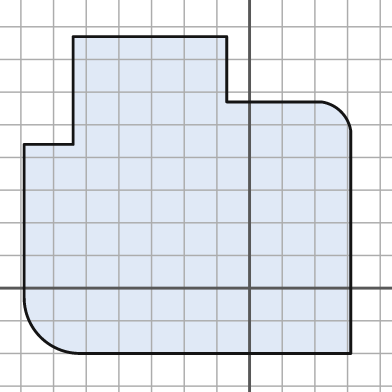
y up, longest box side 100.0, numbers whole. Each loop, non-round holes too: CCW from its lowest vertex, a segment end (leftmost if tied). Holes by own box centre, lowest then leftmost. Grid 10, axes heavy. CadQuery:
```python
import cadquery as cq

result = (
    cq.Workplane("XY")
    .moveTo(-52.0, -20.0)
    .lineTo(31.0, -20.0)
    .lineTo(31.0, 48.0)
    .threePointArc((28.0, 54.0), (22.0, 57.0))
    .lineTo(-7.0, 57.0)
    .lineTo(-7.0, 77.0)
    .lineTo(-54.0, 77.0)
    .lineTo(-54.0, 44.0)
    .lineTo(-69.0, 44.0)
    .lineTo(-69.0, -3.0)
    .threePointArc((-64.0, -15.0), (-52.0, -20.0))
    .close()
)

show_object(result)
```